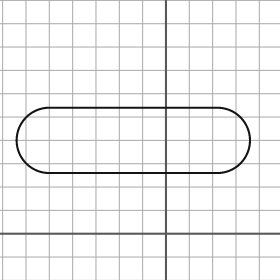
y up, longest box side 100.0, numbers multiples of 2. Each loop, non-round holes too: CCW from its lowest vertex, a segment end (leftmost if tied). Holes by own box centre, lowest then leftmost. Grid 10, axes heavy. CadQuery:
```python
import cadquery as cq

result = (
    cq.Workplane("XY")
    .moveTo(-50.0, 26.0)
    .lineTo(22.0, 26.0)
    .threePointArc((36.0, 40.0), (22.0, 54.0))
    .lineTo(-50.0, 54.0)
    .threePointArc((-64.0, 40.0), (-50.0, 26.0))
    .close()
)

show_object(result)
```